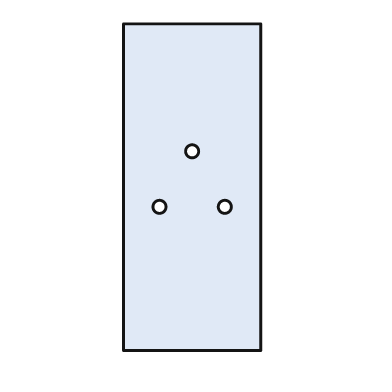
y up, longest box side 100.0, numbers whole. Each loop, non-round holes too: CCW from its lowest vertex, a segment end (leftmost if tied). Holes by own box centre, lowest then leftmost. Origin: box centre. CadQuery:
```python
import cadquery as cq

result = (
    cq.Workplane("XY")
    .moveTo(-21.0, -50.0)
    .lineTo(21.0, -50.0)
    .lineTo(21.0, 50.0)
    .lineTo(-21.0, 50.0)
    .close()
    .moveTo(-10.0, -6.0)
    .circle(2.0)
    .moveTo(10.0, -6.0)
    .circle(2.0)
    .moveTo(0.0, 11.0)
    .circle(2.0)
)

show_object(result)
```